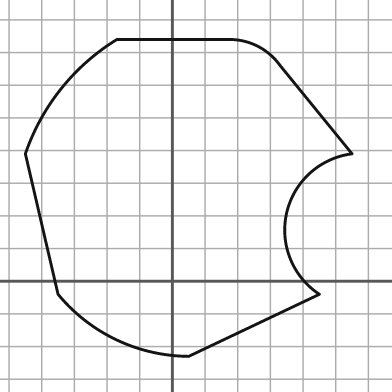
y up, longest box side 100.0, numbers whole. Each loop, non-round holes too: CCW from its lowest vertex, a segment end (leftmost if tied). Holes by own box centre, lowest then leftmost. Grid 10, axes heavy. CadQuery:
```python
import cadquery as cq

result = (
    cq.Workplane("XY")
    .moveTo(5.0, -23.0)
    .lineTo(45.0, -4.0)
    .threePointArc((35.0, 21.0), (55.0, 39.0))
    .lineTo(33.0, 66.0)
    .threePointArc((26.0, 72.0), (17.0, 74.0))
    .lineTo(-17.0, 74.0)
    .threePointArc((-34.0, 59.0), (-45.0, 39.0))
    .lineTo(-35.0, -4.0)
    .threePointArc((-17.0, -18.0), (5.0, -23.0))
    .close()
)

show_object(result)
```